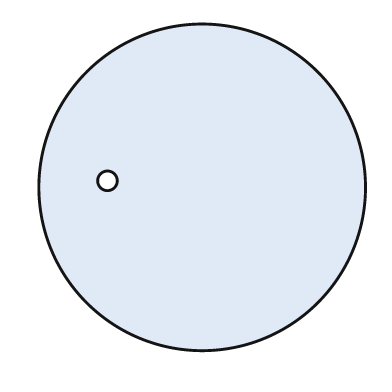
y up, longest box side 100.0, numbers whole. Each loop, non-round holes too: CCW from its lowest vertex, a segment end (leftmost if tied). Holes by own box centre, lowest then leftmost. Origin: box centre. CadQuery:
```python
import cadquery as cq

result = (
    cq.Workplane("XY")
    .moveTo(0.0, 0.0)
    .circle(50.0)
    .moveTo(-29.0, 2.0)
    .circle(3.0)
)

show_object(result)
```